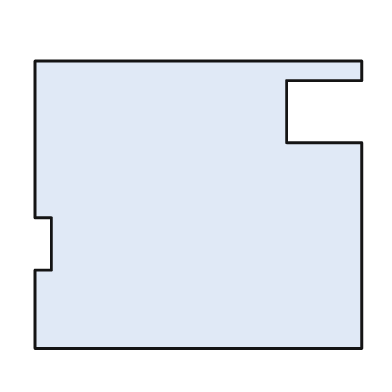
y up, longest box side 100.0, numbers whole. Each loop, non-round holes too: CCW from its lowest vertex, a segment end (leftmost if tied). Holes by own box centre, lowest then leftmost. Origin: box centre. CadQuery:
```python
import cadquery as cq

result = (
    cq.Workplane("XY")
    .moveTo(-50.0, -44.0)
    .lineTo(50.0, -44.0)
    .lineTo(50.0, 19.0)
    .lineTo(27.0, 19.0)
    .lineTo(27.0, 38.0)
    .lineTo(50.0, 38.0)
    .lineTo(50.0, 44.0)
    .lineTo(-50.0, 44.0)
    .lineTo(-50.0, -4.0)
    .lineTo(-45.0, -4.0)
    .lineTo(-45.0, -20.0)
    .lineTo(-50.0, -20.0)
    .close()
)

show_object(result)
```